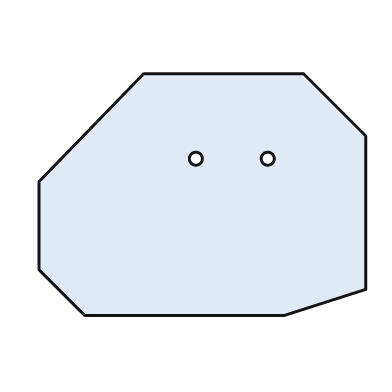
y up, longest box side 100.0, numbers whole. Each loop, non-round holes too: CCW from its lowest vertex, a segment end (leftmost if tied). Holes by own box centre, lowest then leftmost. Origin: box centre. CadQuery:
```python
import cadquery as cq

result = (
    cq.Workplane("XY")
    .moveTo(-36.0, -37.0)
    .lineTo(25.0, -37.0)
    .lineTo(50.0, -29.0)
    .lineTo(50.0, 18.0)
    .lineTo(31.0, 37.0)
    .lineTo(-18.0, 37.0)
    .lineTo(-50.0, 4.0)
    .lineTo(-50.0, -23.0)
    .close()
    .moveTo(-2.0, 11.0)
    .circle(2.0)
    .moveTo(20.0, 11.0)
    .circle(2.0)
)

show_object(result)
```